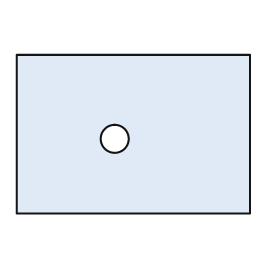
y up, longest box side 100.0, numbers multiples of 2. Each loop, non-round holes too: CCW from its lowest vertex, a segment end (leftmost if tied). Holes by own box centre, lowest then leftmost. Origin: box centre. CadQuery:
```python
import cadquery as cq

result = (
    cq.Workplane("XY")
    .moveTo(-50.0, -34.0)
    .lineTo(50.0, -34.0)
    .lineTo(50.0, 34.0)
    .lineTo(-50.0, 34.0)
    .close()
    .moveTo(-8.0, -2.0)
    .circle(6.0)
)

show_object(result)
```